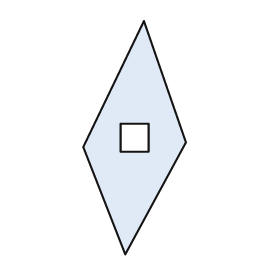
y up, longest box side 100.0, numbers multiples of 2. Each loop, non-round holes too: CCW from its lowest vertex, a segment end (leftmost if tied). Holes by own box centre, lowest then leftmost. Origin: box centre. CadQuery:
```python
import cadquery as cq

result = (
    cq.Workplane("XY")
    .moveTo(-4.0, -50.0)
    .lineTo(22.0, -2.0)
    .lineTo(4.0, 50.0)
    .lineTo(-22.0, -4.0)
    .close()
    .moveTo(-6.0, -6.0)
    .lineTo(6.0, -6.0)
    .lineTo(6.0, 6.0)
    .lineTo(-6.0, 6.0)
    .close()
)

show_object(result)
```